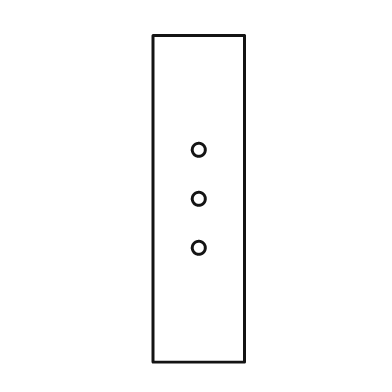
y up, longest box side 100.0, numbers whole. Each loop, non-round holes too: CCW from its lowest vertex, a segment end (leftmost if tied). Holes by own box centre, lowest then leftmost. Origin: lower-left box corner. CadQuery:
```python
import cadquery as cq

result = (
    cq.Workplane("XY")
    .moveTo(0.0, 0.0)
    .lineTo(28.0, 0.0)
    .lineTo(28.0, 100.0)
    .lineTo(0.0, 100.0)
    .close()
    .moveTo(14.0, 35.0)
    .circle(2.0)
    .moveTo(14.0, 50.0)
    .circle(2.0)
    .moveTo(14.0, 65.0)
    .circle(2.0)
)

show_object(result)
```